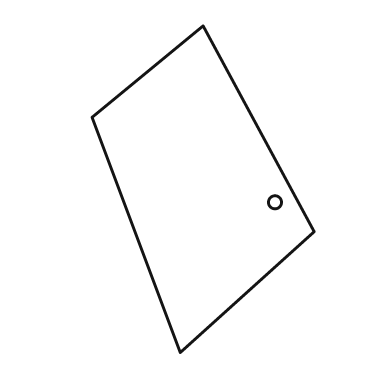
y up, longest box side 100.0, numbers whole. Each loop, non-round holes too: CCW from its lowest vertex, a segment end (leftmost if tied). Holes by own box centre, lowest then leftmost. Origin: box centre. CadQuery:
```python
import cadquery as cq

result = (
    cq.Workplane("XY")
    .moveTo(-7.0, -50.0)
    .lineTo(34.0, -13.0)
    .lineTo(0.0, 50.0)
    .lineTo(-34.0, 22.0)
    .close()
    .moveTo(22.0, -4.0)
    .circle(2.0)
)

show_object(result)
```